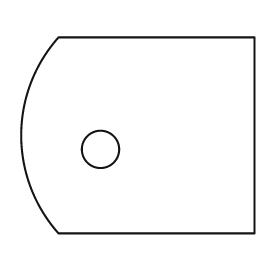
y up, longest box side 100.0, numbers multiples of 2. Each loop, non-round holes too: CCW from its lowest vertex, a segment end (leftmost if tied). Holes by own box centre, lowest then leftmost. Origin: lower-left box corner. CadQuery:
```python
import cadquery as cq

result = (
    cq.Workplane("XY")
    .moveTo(16.0, 0.0)
    .lineTo(100.0, 0.0)
    .lineTo(100.0, 84.0)
    .lineTo(16.0, 84.0)
    .threePointArc((0.0, 42.0), (16.0, 0.0))
    .close()
    .moveTo(34.0, 36.0)
    .circle(8.0)
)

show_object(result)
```